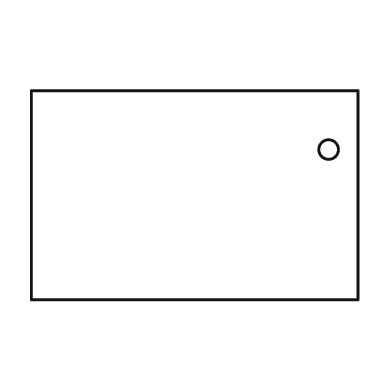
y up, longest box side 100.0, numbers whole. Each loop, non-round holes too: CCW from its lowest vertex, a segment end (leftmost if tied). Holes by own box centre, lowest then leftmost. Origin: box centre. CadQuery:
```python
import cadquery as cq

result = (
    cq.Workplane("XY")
    .moveTo(-50.0, -32.0)
    .lineTo(50.0, -32.0)
    .lineTo(50.0, 32.0)
    .lineTo(-50.0, 32.0)
    .close()
    .moveTo(41.0, 14.0)
    .circle(3.0)
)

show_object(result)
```